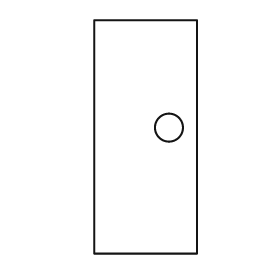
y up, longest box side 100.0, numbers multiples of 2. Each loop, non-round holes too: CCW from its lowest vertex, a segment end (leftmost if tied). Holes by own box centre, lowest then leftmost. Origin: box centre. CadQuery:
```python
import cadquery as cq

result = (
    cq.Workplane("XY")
    .moveTo(-22.0, -50.0)
    .lineTo(22.0, -50.0)
    .lineTo(22.0, 50.0)
    .lineTo(-22.0, 50.0)
    .close()
    .moveTo(10.0, 4.0)
    .circle(6.0)
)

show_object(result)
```